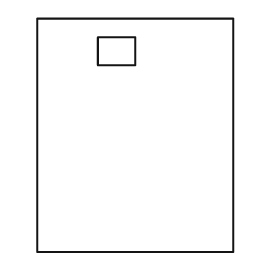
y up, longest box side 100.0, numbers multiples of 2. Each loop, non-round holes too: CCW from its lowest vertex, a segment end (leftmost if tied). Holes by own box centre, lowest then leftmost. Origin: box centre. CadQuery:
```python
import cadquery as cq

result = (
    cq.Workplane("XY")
    .moveTo(-42.0, -50.0)
    .lineTo(42.0, -50.0)
    .lineTo(42.0, 50.0)
    .lineTo(-42.0, 50.0)
    .close()
    .moveTo(-16.0, 30.0)
    .lineTo(0.0, 30.0)
    .lineTo(0.0, 42.0)
    .lineTo(-16.0, 42.0)
    .close()
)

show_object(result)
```